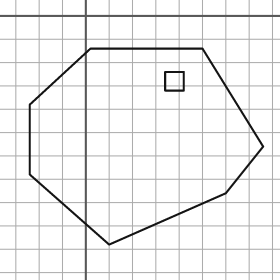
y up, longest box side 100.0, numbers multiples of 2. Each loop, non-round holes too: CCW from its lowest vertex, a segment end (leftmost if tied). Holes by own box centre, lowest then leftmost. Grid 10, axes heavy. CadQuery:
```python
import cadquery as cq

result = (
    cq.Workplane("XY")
    .moveTo(10.0, -98.0)
    .lineTo(60.0, -76.0)
    .lineTo(76.0, -56.0)
    .lineTo(50.0, -14.0)
    .lineTo(2.0, -14.0)
    .lineTo(-24.0, -38.0)
    .lineTo(-24.0, -68.0)
    .close()
    .moveTo(34.0, -32.0)
    .lineTo(42.0, -32.0)
    .lineTo(42.0, -24.0)
    .lineTo(34.0, -24.0)
    .close()
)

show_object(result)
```